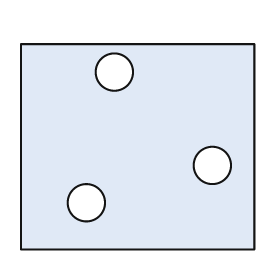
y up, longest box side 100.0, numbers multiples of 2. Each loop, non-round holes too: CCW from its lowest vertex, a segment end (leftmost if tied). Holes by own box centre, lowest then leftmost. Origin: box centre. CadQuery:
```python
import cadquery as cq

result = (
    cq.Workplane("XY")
    .moveTo(-50.0, -44.0)
    .lineTo(50.0, -44.0)
    .lineTo(50.0, 44.0)
    .lineTo(-50.0, 44.0)
    .close()
    .moveTo(-22.0, -24.0)
    .circle(8.0)
    .moveTo(32.0, -8.0)
    .circle(8.0)
    .moveTo(-10.0, 32.0)
    .circle(8.0)
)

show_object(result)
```